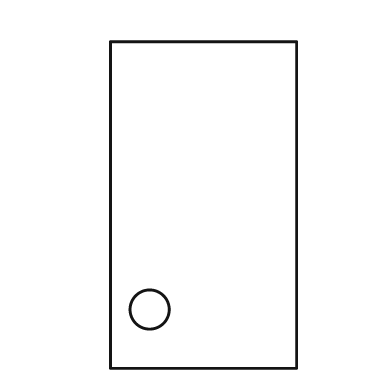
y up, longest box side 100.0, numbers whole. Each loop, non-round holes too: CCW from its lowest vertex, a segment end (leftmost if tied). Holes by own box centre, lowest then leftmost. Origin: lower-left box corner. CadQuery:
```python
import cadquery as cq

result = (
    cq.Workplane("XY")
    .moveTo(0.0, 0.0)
    .lineTo(57.0, 0.0)
    .lineTo(57.0, 100.0)
    .lineTo(0.0, 100.0)
    .close()
    .moveTo(12.0, 18.0)
    .circle(6.0)
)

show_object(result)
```